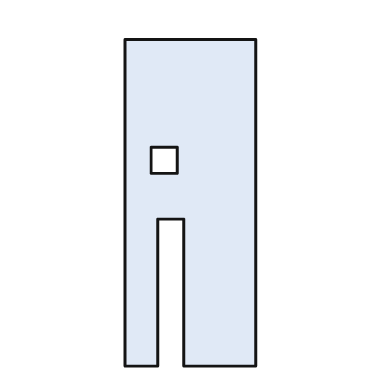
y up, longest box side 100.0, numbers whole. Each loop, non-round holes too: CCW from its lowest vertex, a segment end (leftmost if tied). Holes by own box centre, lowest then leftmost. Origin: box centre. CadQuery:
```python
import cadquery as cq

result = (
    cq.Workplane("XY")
    .moveTo(-20.0, -50.0)
    .lineTo(-10.0, -50.0)
    .lineTo(-10.0, -5.0)
    .lineTo(-2.0, -5.0)
    .lineTo(-2.0, -50.0)
    .lineTo(20.0, -50.0)
    .lineTo(20.0, 50.0)
    .lineTo(-20.0, 50.0)
    .close()
    .moveTo(-12.0, 9.0)
    .lineTo(-4.0, 9.0)
    .lineTo(-4.0, 17.0)
    .lineTo(-12.0, 17.0)
    .close()
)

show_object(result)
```